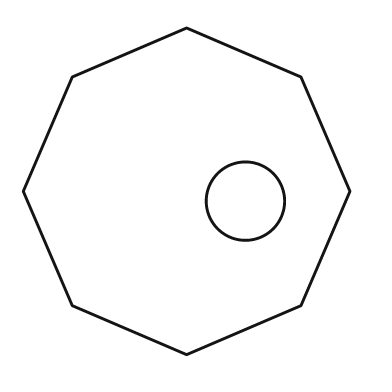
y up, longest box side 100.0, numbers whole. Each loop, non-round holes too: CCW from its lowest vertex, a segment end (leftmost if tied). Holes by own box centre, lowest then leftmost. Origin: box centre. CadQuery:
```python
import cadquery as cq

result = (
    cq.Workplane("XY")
    .moveTo(0.0, -50.0)
    .lineTo(35.0, -35.0)
    .lineTo(50.0, 0.0)
    .lineTo(35.0, 35.0)
    .lineTo(0.0, 50.0)
    .lineTo(-35.0, 35.0)
    .lineTo(-50.0, 0.0)
    .lineTo(-35.0, -35.0)
    .close()
    .moveTo(18.0, -3.0)
    .circle(12.0)
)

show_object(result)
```